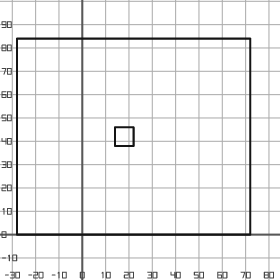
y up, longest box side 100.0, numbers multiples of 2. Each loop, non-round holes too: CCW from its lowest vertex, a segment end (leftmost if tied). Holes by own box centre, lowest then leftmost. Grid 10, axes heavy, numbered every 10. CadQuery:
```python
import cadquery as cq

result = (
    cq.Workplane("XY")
    .moveTo(-28.0, 0.0)
    .lineTo(72.0, 0.0)
    .lineTo(72.0, 84.0)
    .lineTo(-28.0, 84.0)
    .close()
    .moveTo(14.0, 38.0)
    .lineTo(22.0, 38.0)
    .lineTo(22.0, 46.0)
    .lineTo(14.0, 46.0)
    .close()
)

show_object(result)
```